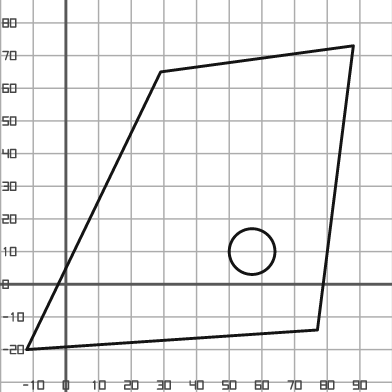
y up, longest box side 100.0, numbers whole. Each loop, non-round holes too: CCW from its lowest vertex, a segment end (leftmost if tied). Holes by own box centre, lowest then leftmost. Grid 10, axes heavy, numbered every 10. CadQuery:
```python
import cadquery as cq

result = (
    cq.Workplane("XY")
    .moveTo(-12.0, -20.0)
    .lineTo(77.0, -14.0)
    .lineTo(88.0, 73.0)
    .lineTo(29.0, 65.0)
    .close()
    .moveTo(57.0, 10.0)
    .circle(7.0)
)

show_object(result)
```